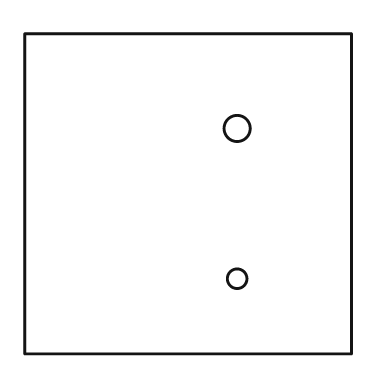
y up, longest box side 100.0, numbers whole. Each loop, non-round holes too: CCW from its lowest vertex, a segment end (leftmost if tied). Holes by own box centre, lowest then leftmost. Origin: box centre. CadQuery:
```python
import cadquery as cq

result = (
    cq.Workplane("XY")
    .moveTo(-50.0, -49.0)
    .lineTo(50.0, -49.0)
    .lineTo(50.0, 49.0)
    .lineTo(-50.0, 49.0)
    .close()
    .moveTo(15.0, -26.0)
    .circle(3.0)
    .moveTo(15.0, 20.0)
    .circle(4.0)
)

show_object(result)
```